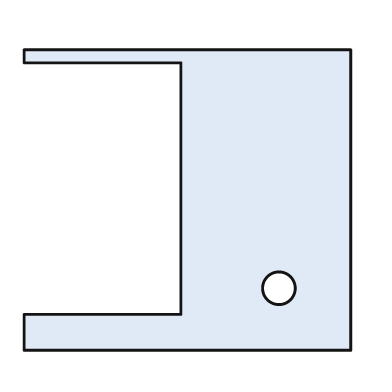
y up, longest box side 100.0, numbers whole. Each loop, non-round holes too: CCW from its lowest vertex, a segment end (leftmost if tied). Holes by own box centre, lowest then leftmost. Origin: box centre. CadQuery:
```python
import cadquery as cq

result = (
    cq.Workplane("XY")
    .moveTo(-50.0, -46.0)
    .lineTo(50.0, -46.0)
    .lineTo(50.0, 46.0)
    .lineTo(-50.0, 46.0)
    .lineTo(-50.0, 42.0)
    .lineTo(-2.0, 42.0)
    .lineTo(-2.0, -35.0)
    .lineTo(-50.0, -35.0)
    .close()
    .moveTo(28.0, -27.0)
    .circle(5.0)
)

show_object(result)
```